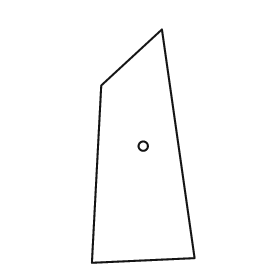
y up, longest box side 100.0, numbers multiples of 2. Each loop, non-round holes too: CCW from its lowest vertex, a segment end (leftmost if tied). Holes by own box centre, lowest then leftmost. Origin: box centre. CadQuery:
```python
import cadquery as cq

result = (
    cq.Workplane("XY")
    .moveTo(-22.0, -50.0)
    .lineTo(22.0, -48.0)
    .lineTo(8.0, 50.0)
    .lineTo(-18.0, 26.0)
    .close()
    .moveTo(0.0, 0.0)
    .circle(2.0)
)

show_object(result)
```